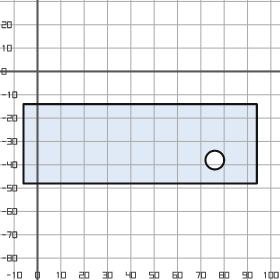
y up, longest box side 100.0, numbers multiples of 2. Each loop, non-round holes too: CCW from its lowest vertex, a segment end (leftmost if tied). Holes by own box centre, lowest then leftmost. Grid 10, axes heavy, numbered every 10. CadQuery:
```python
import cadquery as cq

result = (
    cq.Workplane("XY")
    .moveTo(-6.0, -48.0)
    .lineTo(94.0, -48.0)
    .lineTo(94.0, -14.0)
    .lineTo(-6.0, -14.0)
    .close()
    .moveTo(76.0, -38.0)
    .circle(4.0)
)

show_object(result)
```